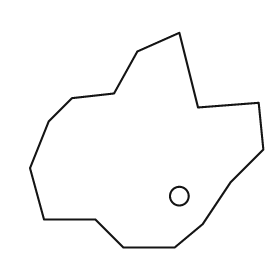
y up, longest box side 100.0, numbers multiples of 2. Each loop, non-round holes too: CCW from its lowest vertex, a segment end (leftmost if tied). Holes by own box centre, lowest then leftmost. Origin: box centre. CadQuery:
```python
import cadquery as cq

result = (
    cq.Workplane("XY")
    .moveTo(-10.0, -46.0)
    .lineTo(12.0, -46.0)
    .lineTo(24.0, -36.0)
    .lineTo(36.0, -18.0)
    .lineTo(50.0, -4.0)
    .lineTo(48.0, 16.0)
    .lineTo(22.0, 14.0)
    .lineTo(14.0, 46.0)
    .lineTo(-4.0, 38.0)
    .lineTo(-14.0, 20.0)
    .lineTo(-32.0, 18.0)
    .lineTo(-42.0, 8.0)
    .lineTo(-50.0, -12.0)
    .lineTo(-44.0, -34.0)
    .lineTo(-22.0, -34.0)
    .close()
    .moveTo(14.0, -24.0)
    .circle(4.0)
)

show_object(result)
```